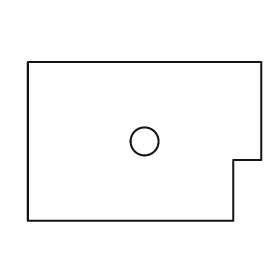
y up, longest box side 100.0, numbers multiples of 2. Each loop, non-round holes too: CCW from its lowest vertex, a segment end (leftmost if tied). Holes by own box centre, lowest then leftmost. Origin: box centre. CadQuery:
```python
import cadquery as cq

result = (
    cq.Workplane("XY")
    .moveTo(-50.0, -34.0)
    .lineTo(38.0, -34.0)
    .lineTo(38.0, -8.0)
    .lineTo(50.0, -8.0)
    .lineTo(50.0, 34.0)
    .lineTo(-50.0, 34.0)
    .close()
    .moveTo(0.0, 0.0)
    .circle(6.0)
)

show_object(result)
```